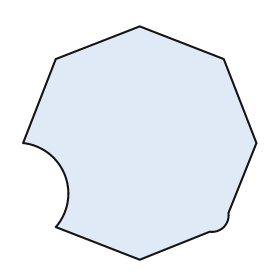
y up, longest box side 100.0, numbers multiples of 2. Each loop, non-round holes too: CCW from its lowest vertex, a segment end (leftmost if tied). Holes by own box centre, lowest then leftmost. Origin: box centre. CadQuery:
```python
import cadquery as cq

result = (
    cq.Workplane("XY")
    .moveTo(0.0, -50.0)
    .lineTo(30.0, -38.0)
    .threePointArc((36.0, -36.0), (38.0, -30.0))
    .lineTo(50.0, 0.0)
    .lineTo(36.0, 36.0)
    .lineTo(0.0, 50.0)
    .lineTo(-36.0, 36.0)
    .lineTo(-50.0, 0.0)
    .threePointArc((-32.0, -14.0), (-36.0, -36.0))
    .close()
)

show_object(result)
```